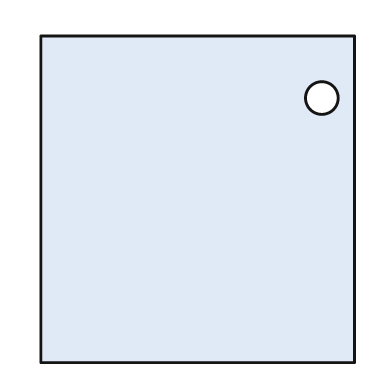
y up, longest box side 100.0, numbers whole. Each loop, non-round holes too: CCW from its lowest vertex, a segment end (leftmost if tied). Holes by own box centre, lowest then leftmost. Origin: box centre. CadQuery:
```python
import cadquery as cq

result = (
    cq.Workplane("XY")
    .moveTo(-48.0, -50.0)
    .lineTo(48.0, -50.0)
    .lineTo(48.0, 50.0)
    .lineTo(-48.0, 50.0)
    .close()
    .moveTo(38.0, 31.0)
    .circle(5.0)
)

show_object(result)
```